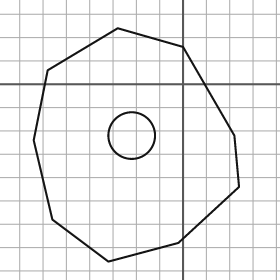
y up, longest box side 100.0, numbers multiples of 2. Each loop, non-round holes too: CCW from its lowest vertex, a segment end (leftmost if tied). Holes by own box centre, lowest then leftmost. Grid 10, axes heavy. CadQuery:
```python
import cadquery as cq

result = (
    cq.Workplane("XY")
    .moveTo(-32.0, -76.0)
    .lineTo(-2.0, -68.0)
    .lineTo(24.0, -44.0)
    .lineTo(22.0, -22.0)
    .lineTo(0.0, 16.0)
    .lineTo(-28.0, 24.0)
    .lineTo(-58.0, 6.0)
    .lineTo(-64.0, -24.0)
    .lineTo(-56.0, -58.0)
    .close()
    .moveTo(-22.0, -22.0)
    .circle(10.0)
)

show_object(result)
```